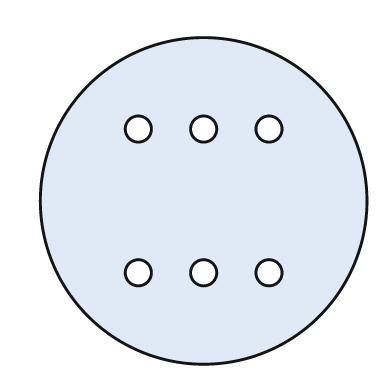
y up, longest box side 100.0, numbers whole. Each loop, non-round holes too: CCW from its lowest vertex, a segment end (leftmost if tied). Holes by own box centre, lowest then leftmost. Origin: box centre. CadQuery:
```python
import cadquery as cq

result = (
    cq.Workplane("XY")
    .moveTo(0.0, 0.0)
    .circle(50.0)
    .moveTo(-20.0, -22.0)
    .circle(4.0)
    .moveTo(0.0, -22.0)
    .circle(4.0)
    .moveTo(20.0, -22.0)
    .circle(4.0)
    .moveTo(-20.0, 22.0)
    .circle(4.0)
    .moveTo(0.0, 22.0)
    .circle(4.0)
    .moveTo(20.0, 22.0)
    .circle(4.0)
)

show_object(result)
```